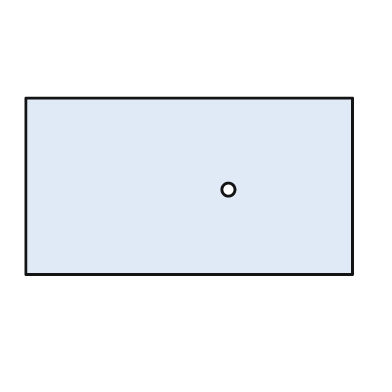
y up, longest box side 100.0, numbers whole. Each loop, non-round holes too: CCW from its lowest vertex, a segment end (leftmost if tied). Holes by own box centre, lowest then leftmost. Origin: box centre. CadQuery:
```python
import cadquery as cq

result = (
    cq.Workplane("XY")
    .moveTo(-50.0, -27.0)
    .lineTo(50.0, -27.0)
    .lineTo(50.0, 27.0)
    .lineTo(-50.0, 27.0)
    .close()
    .moveTo(12.0, -1.0)
    .circle(2.0)
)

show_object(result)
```